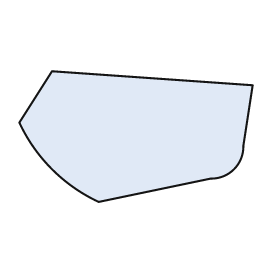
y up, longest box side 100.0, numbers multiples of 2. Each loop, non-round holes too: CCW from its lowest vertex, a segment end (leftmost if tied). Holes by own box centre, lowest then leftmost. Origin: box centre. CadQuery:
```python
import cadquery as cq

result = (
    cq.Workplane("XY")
    .moveTo(-16.0, -28.0)
    .lineTo(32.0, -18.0)
    .threePointArc((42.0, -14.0), (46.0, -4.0))
    .lineTo(50.0, 22.0)
    .lineTo(-36.0, 28.0)
    .lineTo(-50.0, 6.0)
    .threePointArc((-36.0, -14.0), (-16.0, -28.0))
    .close()
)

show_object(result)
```